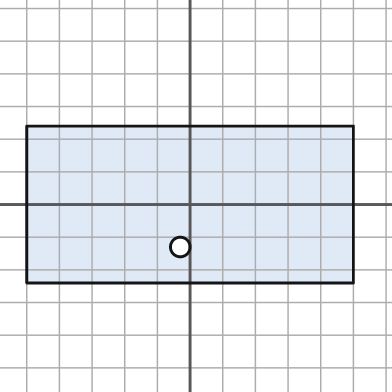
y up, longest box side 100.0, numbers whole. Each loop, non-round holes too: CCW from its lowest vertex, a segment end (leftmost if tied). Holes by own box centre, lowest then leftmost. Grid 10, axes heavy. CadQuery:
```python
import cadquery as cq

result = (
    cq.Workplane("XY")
    .moveTo(-50.0, -24.0)
    .lineTo(50.0, -24.0)
    .lineTo(50.0, 24.0)
    .lineTo(-50.0, 24.0)
    .close()
    .moveTo(-3.0, -13.0)
    .circle(3.0)
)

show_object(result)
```